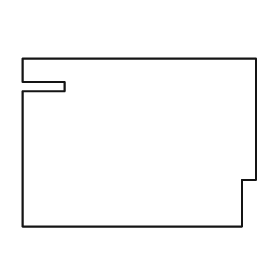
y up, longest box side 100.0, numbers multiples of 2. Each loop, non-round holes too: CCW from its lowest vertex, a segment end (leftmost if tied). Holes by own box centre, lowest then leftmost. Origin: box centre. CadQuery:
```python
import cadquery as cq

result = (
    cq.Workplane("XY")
    .moveTo(-50.0, -36.0)
    .lineTo(44.0, -36.0)
    .lineTo(44.0, -16.0)
    .lineTo(50.0, -16.0)
    .lineTo(50.0, 36.0)
    .lineTo(-50.0, 36.0)
    .lineTo(-50.0, 26.0)
    .lineTo(-32.0, 26.0)
    .lineTo(-32.0, 22.0)
    .lineTo(-50.0, 22.0)
    .close()
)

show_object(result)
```